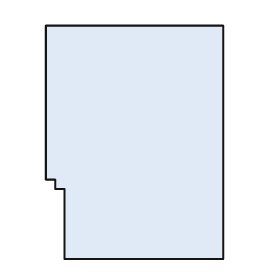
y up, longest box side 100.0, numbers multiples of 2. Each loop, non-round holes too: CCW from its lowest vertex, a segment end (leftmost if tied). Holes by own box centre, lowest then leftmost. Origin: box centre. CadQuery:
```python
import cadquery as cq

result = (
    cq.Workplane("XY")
    .moveTo(-30.0, -50.0)
    .lineTo(38.0, -50.0)
    .lineTo(38.0, 50.0)
    .lineTo(-38.0, 50.0)
    .lineTo(-38.0, -16.0)
    .lineTo(-34.0, -16.0)
    .lineTo(-34.0, -20.0)
    .lineTo(-30.0, -20.0)
    .close()
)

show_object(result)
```